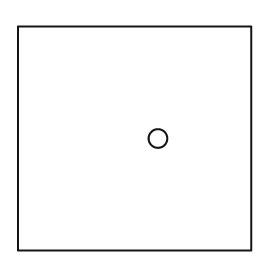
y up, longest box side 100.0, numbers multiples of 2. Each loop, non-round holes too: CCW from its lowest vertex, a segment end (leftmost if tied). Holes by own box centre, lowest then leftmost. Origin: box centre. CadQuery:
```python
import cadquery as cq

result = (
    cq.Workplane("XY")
    .moveTo(-50.0, -48.0)
    .lineTo(50.0, -48.0)
    .lineTo(50.0, 48.0)
    .lineTo(-50.0, 48.0)
    .close()
    .moveTo(10.0, 0.0)
    .circle(4.0)
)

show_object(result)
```